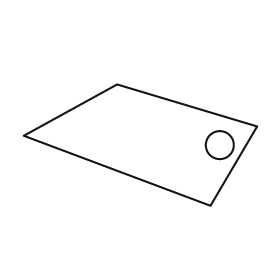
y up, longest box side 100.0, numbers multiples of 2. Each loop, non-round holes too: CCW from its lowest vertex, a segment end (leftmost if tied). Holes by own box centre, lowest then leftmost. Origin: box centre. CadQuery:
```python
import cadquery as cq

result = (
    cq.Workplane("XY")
    .moveTo(30.0, -26.0)
    .lineTo(50.0, 8.0)
    .lineTo(-10.0, 26.0)
    .lineTo(-50.0, 4.0)
    .close()
    .moveTo(34.0, 0.0)
    .circle(6.0)
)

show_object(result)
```